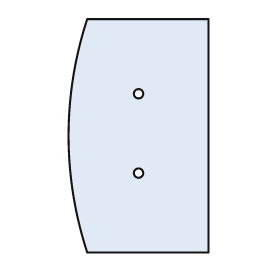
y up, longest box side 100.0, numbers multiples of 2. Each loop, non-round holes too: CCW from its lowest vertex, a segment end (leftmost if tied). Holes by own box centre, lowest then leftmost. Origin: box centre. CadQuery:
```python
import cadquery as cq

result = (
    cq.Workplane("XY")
    .moveTo(-22.0, -50.0)
    .lineTo(30.0, -50.0)
    .lineTo(30.0, 50.0)
    .lineTo(-22.0, 50.0)
    .threePointArc((-30.0, 0.0), (-22.0, -50.0))
    .close()
    .moveTo(0.0, -16.0)
    .circle(2.0)
    .moveTo(0.0, 18.0)
    .circle(2.0)
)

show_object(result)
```